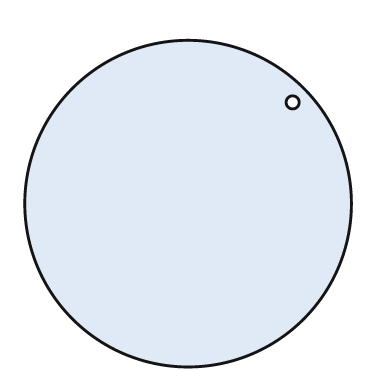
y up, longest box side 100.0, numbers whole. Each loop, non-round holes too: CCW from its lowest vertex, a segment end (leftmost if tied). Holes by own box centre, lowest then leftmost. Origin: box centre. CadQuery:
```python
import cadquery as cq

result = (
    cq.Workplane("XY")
    .moveTo(0.0, 0.0)
    .circle(50.0)
    .moveTo(32.0, 31.0)
    .circle(2.0)
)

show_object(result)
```